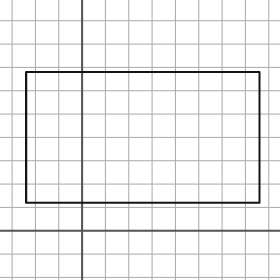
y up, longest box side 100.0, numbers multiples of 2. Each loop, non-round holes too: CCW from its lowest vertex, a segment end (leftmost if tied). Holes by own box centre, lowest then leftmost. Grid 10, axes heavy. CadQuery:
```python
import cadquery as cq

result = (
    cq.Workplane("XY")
    .moveTo(-24.0, 12.0)
    .lineTo(76.0, 12.0)
    .lineTo(76.0, 68.0)
    .lineTo(-24.0, 68.0)
    .close()
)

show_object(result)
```